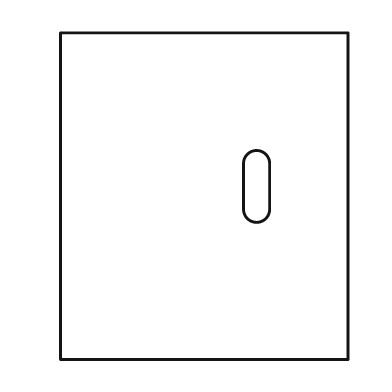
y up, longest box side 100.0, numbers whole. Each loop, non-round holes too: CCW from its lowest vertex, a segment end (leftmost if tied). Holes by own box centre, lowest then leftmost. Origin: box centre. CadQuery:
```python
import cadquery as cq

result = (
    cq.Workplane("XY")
    .moveTo(-44.0, -50.0)
    .lineTo(44.0, -50.0)
    .lineTo(44.0, 50.0)
    .lineTo(-44.0, 50.0)
    .close()
    .moveTo(12.0, -4.0)
    .threePointArc((16.0, -8.0), (20.0, -4.0))
    .lineTo(20.0, 10.0)
    .threePointArc((16.0, 14.0), (12.0, 10.0))
    .close()
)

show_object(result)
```